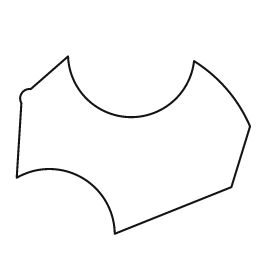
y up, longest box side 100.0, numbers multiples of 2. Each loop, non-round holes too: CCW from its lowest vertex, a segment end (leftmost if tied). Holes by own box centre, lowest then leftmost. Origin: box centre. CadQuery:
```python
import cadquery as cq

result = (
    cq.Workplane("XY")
    .moveTo(-8.0, -38.0)
    .lineTo(42.0, -18.0)
    .lineTo(50.0, 8.0)
    .threePointArc((40.0, 24.0), (26.0, 36.0))
    .threePointArc((-2.0, 12.0), (-28.0, 38.0))
    .lineTo(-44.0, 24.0)
    .threePointArc((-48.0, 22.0), (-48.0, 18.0))
    .lineTo(-50.0, -14.0)
    .threePointArc((-22.0, -14.0), (-8.0, -38.0))
    .close()
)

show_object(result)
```